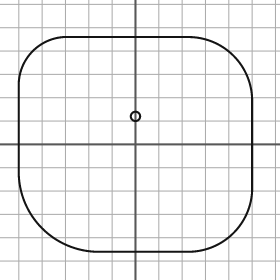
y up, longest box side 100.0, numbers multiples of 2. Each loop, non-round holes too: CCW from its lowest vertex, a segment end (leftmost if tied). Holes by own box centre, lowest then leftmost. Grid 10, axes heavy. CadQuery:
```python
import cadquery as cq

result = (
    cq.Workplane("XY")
    .moveTo(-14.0, -46.0)
    .lineTo(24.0, -46.0)
    .threePointArc((42.0, -38.0), (50.0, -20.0))
    .lineTo(50.0, 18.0)
    .threePointArc((42.0, 38.0), (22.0, 46.0))
    .lineTo(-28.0, 46.0)
    .threePointArc((-44.0, 40.0), (-50.0, 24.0))
    .lineTo(-50.0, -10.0)
    .threePointArc((-40.0, -36.0), (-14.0, -46.0))
    .close()
    .moveTo(0.0, 12.0)
    .circle(2.0)
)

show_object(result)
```